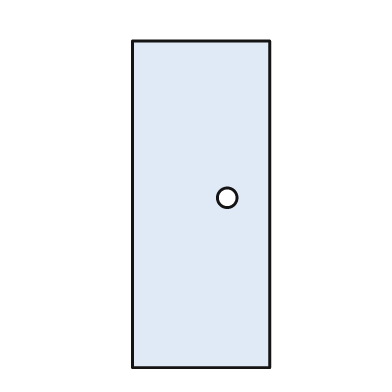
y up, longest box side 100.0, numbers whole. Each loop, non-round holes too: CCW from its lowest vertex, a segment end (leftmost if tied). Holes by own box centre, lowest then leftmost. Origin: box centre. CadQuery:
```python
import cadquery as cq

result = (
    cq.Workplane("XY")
    .moveTo(-21.0, -50.0)
    .lineTo(21.0, -50.0)
    .lineTo(21.0, 50.0)
    .lineTo(-21.0, 50.0)
    .close()
    .moveTo(8.0, 2.0)
    .circle(3.0)
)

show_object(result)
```